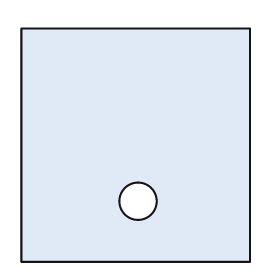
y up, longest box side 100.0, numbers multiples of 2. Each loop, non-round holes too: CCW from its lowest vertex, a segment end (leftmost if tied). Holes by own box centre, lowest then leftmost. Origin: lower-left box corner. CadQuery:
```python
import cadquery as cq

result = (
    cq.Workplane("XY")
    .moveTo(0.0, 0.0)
    .lineTo(98.0, 0.0)
    .lineTo(98.0, 100.0)
    .lineTo(0.0, 100.0)
    .close()
    .moveTo(50.0, 26.0)
    .circle(8.0)
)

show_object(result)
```